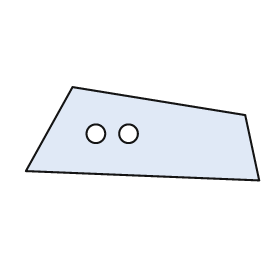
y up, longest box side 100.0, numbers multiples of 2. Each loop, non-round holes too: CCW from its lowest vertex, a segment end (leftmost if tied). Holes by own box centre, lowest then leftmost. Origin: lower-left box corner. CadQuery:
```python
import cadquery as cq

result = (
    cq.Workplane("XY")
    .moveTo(100.0, 0.0)
    .lineTo(94.0, 28.0)
    .lineTo(20.0, 40.0)
    .lineTo(0.0, 4.0)
    .close()
    .moveTo(30.0, 20.0)
    .circle(4.0)
    .moveTo(44.0, 20.0)
    .circle(4.0)
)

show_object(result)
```